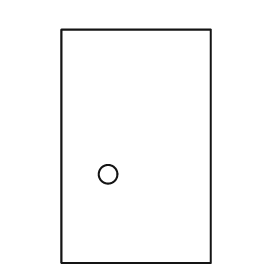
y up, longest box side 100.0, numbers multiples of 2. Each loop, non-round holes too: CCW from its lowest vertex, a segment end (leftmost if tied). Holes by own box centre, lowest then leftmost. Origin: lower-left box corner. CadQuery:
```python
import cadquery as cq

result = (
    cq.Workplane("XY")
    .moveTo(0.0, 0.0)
    .lineTo(64.0, 0.0)
    .lineTo(64.0, 100.0)
    .lineTo(0.0, 100.0)
    .close()
    .moveTo(20.0, 38.0)
    .circle(4.0)
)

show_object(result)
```